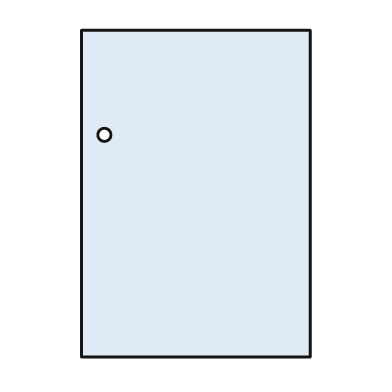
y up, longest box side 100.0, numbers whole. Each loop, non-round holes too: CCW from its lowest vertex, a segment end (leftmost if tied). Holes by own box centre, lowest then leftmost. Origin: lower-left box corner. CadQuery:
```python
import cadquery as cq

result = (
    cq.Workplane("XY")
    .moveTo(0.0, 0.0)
    .lineTo(70.0, 0.0)
    .lineTo(70.0, 100.0)
    .lineTo(0.0, 100.0)
    .close()
    .moveTo(7.0, 68.0)
    .circle(2.0)
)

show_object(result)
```